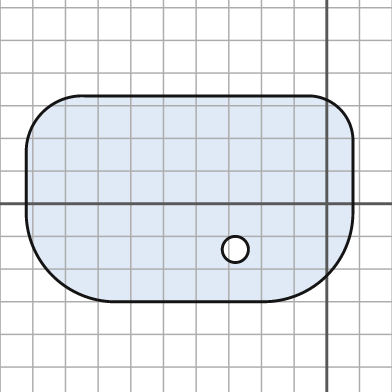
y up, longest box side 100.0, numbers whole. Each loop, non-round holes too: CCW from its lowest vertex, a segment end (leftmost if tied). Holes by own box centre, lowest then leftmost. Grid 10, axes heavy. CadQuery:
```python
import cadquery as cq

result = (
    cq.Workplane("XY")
    .moveTo(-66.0, -30.0)
    .lineTo(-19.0, -30.0)
    .threePointArc((0.0, -22.0), (8.0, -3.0))
    .lineTo(8.0, 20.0)
    .threePointArc((4.0, 29.0), (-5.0, 33.0))
    .lineTo(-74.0, 33.0)
    .threePointArc((-87.0, 28.0), (-92.0, 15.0))
    .lineTo(-92.0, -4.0)
    .threePointArc((-84.0, -22.0), (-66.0, -30.0))
    .close()
    .moveTo(-28.0, -14.0)
    .circle(4.0)
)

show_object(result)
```